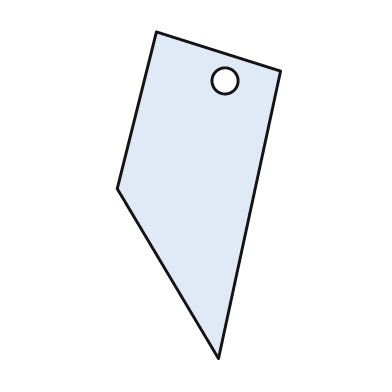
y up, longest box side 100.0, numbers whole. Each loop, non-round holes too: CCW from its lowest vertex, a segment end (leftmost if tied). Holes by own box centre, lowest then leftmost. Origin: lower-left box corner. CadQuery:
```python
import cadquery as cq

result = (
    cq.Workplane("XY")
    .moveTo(31.0, 0.0)
    .lineTo(50.0, 88.0)
    .lineTo(12.0, 100.0)
    .lineTo(0.0, 52.0)
    .close()
    .moveTo(33.0, 85.0)
    .circle(4.0)
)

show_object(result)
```